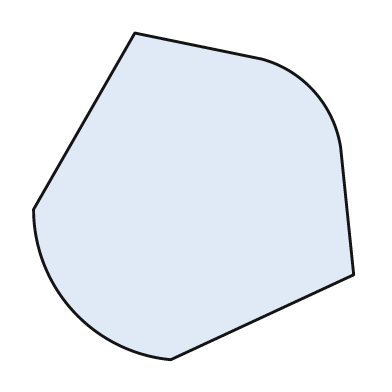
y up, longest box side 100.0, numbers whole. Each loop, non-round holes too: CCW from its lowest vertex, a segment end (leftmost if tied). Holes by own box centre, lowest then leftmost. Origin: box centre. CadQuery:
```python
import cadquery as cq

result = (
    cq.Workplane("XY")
    .moveTo(-7.0, -50.0)
    .lineTo(49.0, -24.0)
    .lineTo(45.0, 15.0)
    .threePointArc((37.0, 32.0), (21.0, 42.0))
    .lineTo(-18.0, 50.0)
    .lineTo(-49.0, -4.0)
    .threePointArc((-37.0, -35.0), (-7.0, -50.0))
    .close()
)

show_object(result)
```